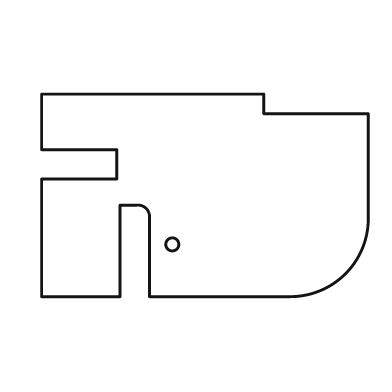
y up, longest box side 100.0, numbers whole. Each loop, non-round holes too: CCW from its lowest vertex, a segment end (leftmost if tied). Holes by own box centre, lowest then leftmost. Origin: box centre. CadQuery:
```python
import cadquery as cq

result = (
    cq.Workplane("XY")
    .moveTo(-50.0, -31.0)
    .lineTo(-26.0, -31.0)
    .lineTo(-26.0, -3.0)
    .lineTo(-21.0, -3.0)
    .threePointArc((-18.0, -4.0), (-17.0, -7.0))
    .lineTo(-17.0, -31.0)
    .lineTo(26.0, -31.0)
    .threePointArc((43.0, -24.0), (50.0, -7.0))
    .lineTo(50.0, 25.0)
    .lineTo(18.0, 25.0)
    .lineTo(18.0, 31.0)
    .lineTo(-50.0, 31.0)
    .lineTo(-50.0, 14.0)
    .lineTo(-27.0, 14.0)
    .lineTo(-27.0, 5.0)
    .lineTo(-50.0, 5.0)
    .close()
    .moveTo(-10.0, -15.0)
    .circle(2.0)
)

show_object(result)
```